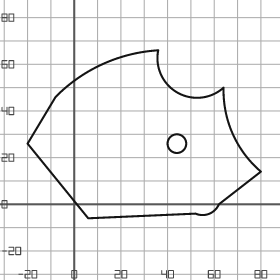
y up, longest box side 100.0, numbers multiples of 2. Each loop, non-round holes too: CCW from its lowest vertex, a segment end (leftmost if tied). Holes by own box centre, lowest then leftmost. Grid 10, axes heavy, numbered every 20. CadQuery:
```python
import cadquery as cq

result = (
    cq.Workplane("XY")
    .moveTo(6.0, -6.0)
    .lineTo(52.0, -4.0)
    .threePointArc((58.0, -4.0), (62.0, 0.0))
    .lineTo(80.0, 14.0)
    .threePointArc((68.0, 30.0), (64.0, 50.0))
    .threePointArc((44.0, 48.0), (36.0, 66.0))
    .threePointArc((12.0, 60.0), (-8.0, 46.0))
    .lineTo(-20.0, 26.0)
    .close()
    .moveTo(44.0, 26.0)
    .circle(4.0)
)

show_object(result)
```